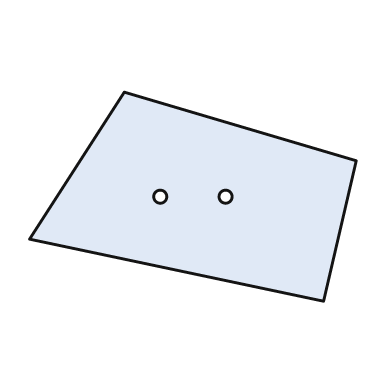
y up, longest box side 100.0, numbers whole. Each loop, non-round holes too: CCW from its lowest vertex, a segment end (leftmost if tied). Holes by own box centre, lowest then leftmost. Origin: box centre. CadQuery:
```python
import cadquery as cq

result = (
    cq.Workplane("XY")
    .moveTo(40.0, -32.0)
    .lineTo(50.0, 11.0)
    .lineTo(-21.0, 32.0)
    .lineTo(-50.0, -13.0)
    .close()
    .moveTo(-10.0, 0.0)
    .circle(2.0)
    .moveTo(10.0, 0.0)
    .circle(2.0)
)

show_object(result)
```